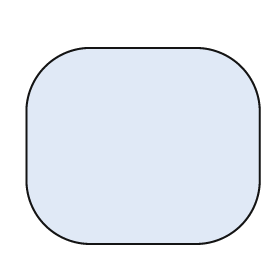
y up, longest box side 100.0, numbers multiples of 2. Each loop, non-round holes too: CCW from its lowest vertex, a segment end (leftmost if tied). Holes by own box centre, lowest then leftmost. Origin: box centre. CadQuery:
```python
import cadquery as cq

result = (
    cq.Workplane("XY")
    .moveTo(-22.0, -42.0)
    .lineTo(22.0, -42.0)
    .threePointArc((42.0, -34.0), (50.0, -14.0))
    .lineTo(50.0, 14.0)
    .threePointArc((42.0, 34.0), (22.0, 42.0))
    .lineTo(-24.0, 42.0)
    .threePointArc((-42.0, 34.0), (-50.0, 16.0))
    .lineTo(-50.0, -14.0)
    .threePointArc((-42.0, -34.0), (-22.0, -42.0))
    .close()
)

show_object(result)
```